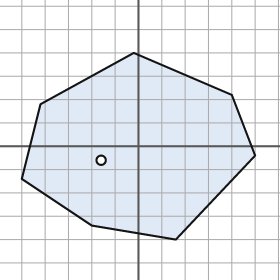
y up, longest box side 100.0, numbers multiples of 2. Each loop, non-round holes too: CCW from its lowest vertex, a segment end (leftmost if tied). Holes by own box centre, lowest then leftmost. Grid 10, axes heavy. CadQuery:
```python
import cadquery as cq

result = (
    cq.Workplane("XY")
    .moveTo(16.0, -40.0)
    .lineTo(50.0, -4.0)
    .lineTo(40.0, 22.0)
    .lineTo(-2.0, 40.0)
    .lineTo(-42.0, 18.0)
    .lineTo(-50.0, -14.0)
    .lineTo(-20.0, -34.0)
    .close()
    .moveTo(-16.0, -6.0)
    .circle(2.0)
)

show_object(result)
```